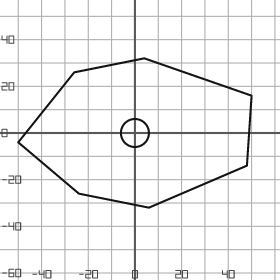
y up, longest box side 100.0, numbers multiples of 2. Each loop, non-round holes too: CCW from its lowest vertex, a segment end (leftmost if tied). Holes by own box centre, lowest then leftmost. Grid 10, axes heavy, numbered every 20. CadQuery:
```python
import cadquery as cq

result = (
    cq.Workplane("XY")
    .moveTo(6.0, -32.0)
    .lineTo(48.0, -14.0)
    .lineTo(50.0, 16.0)
    .lineTo(4.0, 32.0)
    .lineTo(-26.0, 26.0)
    .lineTo(-50.0, -4.0)
    .lineTo(-24.0, -26.0)
    .close()
    .moveTo(0.0, 0.0)
    .circle(6.0)
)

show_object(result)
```